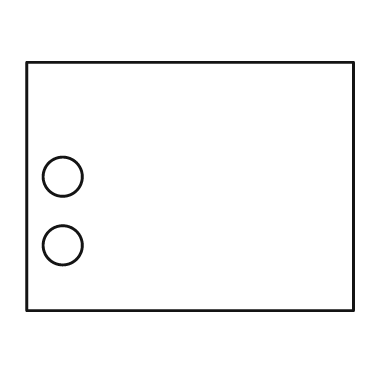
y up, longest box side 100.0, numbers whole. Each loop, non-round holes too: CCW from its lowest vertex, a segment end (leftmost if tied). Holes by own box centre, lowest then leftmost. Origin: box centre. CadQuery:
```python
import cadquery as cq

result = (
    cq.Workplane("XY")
    .moveTo(-50.0, -38.0)
    .lineTo(50.0, -38.0)
    .lineTo(50.0, 38.0)
    .lineTo(-50.0, 38.0)
    .close()
    .moveTo(-39.0, -18.0)
    .circle(6.0)
    .moveTo(-39.0, 3.0)
    .circle(6.0)
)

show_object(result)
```